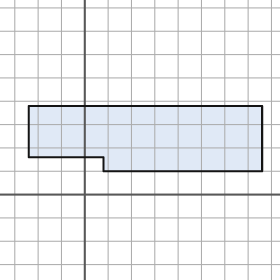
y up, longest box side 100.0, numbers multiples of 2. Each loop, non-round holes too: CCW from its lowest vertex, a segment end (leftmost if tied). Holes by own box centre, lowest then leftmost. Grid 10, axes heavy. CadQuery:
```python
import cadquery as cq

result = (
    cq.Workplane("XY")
    .moveTo(8.0, 10.0)
    .lineTo(76.0, 10.0)
    .lineTo(76.0, 38.0)
    .lineTo(-24.0, 38.0)
    .lineTo(-24.0, 16.0)
    .lineTo(8.0, 16.0)
    .close()
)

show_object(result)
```